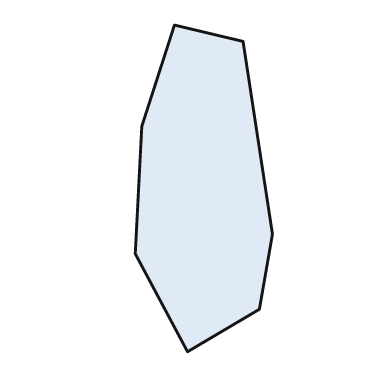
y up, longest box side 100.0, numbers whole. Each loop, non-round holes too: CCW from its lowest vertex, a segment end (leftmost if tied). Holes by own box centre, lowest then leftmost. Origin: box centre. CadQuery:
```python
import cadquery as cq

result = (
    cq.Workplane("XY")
    .moveTo(-5.0, -50.0)
    .lineTo(17.0, -37.0)
    .lineTo(21.0, -14.0)
    .lineTo(12.0, 45.0)
    .lineTo(-9.0, 50.0)
    .lineTo(-19.0, 19.0)
    .lineTo(-21.0, -20.0)
    .close()
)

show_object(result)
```